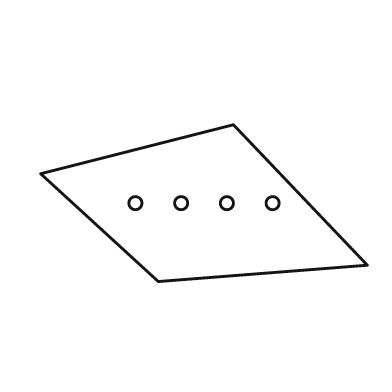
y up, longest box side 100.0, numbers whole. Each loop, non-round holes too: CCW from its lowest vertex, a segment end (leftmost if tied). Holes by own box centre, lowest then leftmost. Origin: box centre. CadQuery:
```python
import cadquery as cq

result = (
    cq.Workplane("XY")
    .moveTo(-14.0, -24.0)
    .lineTo(50.0, -19.0)
    .lineTo(9.0, 24.0)
    .lineTo(-50.0, 9.0)
    .close()
    .moveTo(-21.0, 0.0)
    .circle(2.0)
    .moveTo(-7.0, 0.0)
    .circle(2.0)
    .moveTo(7.0, 0.0)
    .circle(2.0)
    .moveTo(21.0, 0.0)
    .circle(2.0)
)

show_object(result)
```